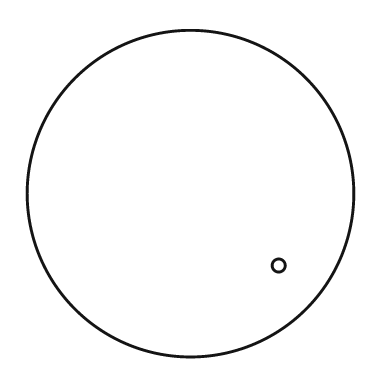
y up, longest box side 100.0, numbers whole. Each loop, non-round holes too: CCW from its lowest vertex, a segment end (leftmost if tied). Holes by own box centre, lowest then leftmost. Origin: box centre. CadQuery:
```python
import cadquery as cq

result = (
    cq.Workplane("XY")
    .moveTo(0.0, 0.0)
    .circle(50.0)
    .moveTo(27.0, -22.0)
    .circle(2.0)
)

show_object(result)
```